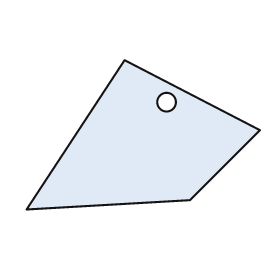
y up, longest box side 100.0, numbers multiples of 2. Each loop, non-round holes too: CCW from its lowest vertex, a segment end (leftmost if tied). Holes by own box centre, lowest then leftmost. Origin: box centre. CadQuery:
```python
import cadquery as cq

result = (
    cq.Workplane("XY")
    .moveTo(-50.0, -32.0)
    .lineTo(20.0, -28.0)
    .lineTo(50.0, 2.0)
    .lineTo(-8.0, 32.0)
    .close()
    .moveTo(10.0, 14.0)
    .circle(4.0)
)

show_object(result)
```